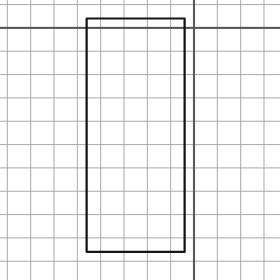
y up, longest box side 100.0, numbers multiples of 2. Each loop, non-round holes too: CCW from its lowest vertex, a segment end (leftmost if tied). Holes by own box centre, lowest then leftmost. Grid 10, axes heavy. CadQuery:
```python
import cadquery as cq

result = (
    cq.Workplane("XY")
    .moveTo(-46.0, -96.0)
    .lineTo(-4.0, -96.0)
    .lineTo(-4.0, 4.0)
    .lineTo(-46.0, 4.0)
    .close()
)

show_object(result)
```